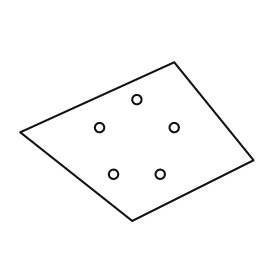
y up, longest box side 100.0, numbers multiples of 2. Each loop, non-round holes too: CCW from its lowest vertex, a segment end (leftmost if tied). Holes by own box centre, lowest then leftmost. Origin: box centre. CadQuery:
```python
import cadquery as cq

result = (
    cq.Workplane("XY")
    .moveTo(-2.0, -34.0)
    .lineTo(50.0, -8.0)
    .lineTo(16.0, 34.0)
    .lineTo(-50.0, 4.0)
    .close()
    .moveTo(-10.0, -14.0)
    .circle(2.0)
    .moveTo(10.0, -14.0)
    .circle(2.0)
    .moveTo(-16.0, 6.0)
    .circle(2.0)
    .moveTo(16.0, 6.0)
    .circle(2.0)
    .moveTo(0.0, 18.0)
    .circle(2.0)
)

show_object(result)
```